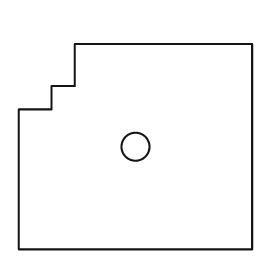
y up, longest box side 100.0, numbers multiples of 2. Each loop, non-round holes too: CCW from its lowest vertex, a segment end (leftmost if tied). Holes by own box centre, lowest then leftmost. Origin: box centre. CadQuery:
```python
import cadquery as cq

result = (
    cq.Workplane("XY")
    .moveTo(-50.0, -44.0)
    .lineTo(50.0, -44.0)
    .lineTo(50.0, 44.0)
    .lineTo(-26.0, 44.0)
    .lineTo(-26.0, 26.0)
    .lineTo(-36.0, 26.0)
    .lineTo(-36.0, 16.0)
    .lineTo(-50.0, 16.0)
    .close()
    .moveTo(0.0, 0.0)
    .circle(6.0)
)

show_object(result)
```